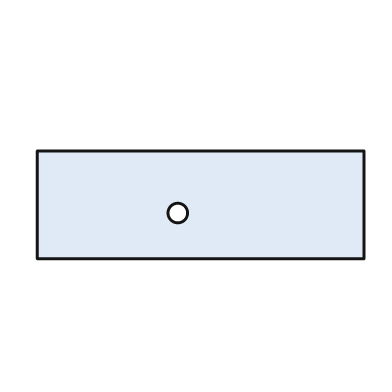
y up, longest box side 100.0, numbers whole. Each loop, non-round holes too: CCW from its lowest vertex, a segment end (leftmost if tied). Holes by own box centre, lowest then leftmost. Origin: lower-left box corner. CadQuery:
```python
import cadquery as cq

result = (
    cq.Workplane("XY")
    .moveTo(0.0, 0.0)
    .lineTo(100.0, 0.0)
    .lineTo(100.0, 33.0)
    .lineTo(0.0, 33.0)
    .close()
    .moveTo(43.0, 14.0)
    .circle(3.0)
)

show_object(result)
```